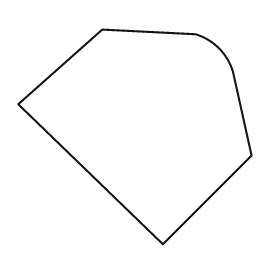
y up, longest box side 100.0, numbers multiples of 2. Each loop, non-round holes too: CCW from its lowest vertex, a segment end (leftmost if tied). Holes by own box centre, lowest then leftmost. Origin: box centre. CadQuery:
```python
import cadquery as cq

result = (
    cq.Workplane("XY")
    .moveTo(12.0, -46.0)
    .lineTo(50.0, -8.0)
    .lineTo(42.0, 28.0)
    .threePointArc((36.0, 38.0), (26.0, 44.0))
    .lineTo(-14.0, 46.0)
    .lineTo(-50.0, 14.0)
    .close()
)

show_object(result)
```